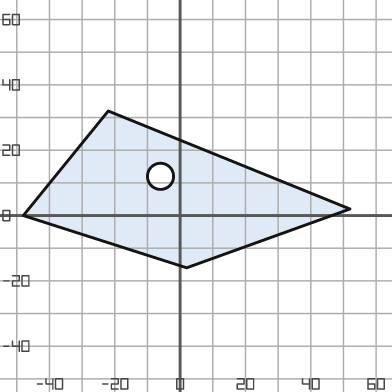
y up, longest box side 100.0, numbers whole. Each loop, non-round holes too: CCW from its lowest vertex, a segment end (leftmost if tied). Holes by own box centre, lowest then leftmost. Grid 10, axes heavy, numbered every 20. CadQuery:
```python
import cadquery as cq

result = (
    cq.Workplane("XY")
    .moveTo(2.0, -16.0)
    .lineTo(52.0, 2.0)
    .lineTo(-22.0, 32.0)
    .lineTo(-48.0, 0.0)
    .close()
    .moveTo(-6.0, 12.0)
    .circle(4.0)
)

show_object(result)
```